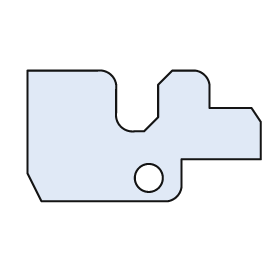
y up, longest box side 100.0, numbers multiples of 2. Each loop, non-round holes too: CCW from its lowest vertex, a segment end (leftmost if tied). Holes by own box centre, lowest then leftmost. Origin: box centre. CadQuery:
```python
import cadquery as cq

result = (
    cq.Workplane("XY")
    .moveTo(-44.0, -28.0)
    .lineTo(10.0, -28.0)
    .threePointArc((14.0, -26.0), (16.0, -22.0))
    .lineTo(16.0, -10.0)
    .lineTo(50.0, -10.0)
    .lineTo(50.0, 6.0)
    .lineTo(46.0, 12.0)
    .lineTo(28.0, 12.0)
    .lineTo(28.0, 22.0)
    .threePointArc((26.0, 26.0), (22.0, 28.0))
    .lineTo(12.0, 28.0)
    .lineTo(6.0, 22.0)
    .lineTo(6.0, 8.0)
    .lineTo(0.0, 2.0)
    .lineTo(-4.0, 2.0)
    .threePointArc((-10.0, 4.0), (-12.0, 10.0))
    .lineTo(-12.0, 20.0)
    .threePointArc((-14.0, 26.0), (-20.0, 28.0))
    .lineTo(-50.0, 28.0)
    .lineTo(-50.0, -16.0)
    .close()
    .moveTo(2.0, -18.0)
    .circle(6.0)
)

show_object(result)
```